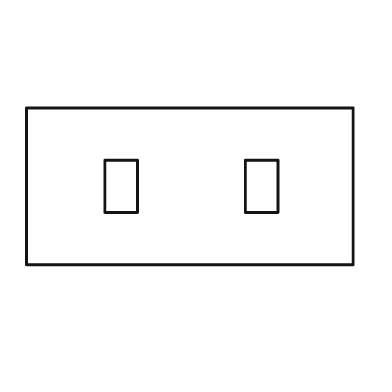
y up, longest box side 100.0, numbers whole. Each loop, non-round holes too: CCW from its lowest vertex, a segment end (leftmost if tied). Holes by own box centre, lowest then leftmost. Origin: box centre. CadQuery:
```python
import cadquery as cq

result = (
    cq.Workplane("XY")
    .moveTo(-50.0, -24.0)
    .lineTo(50.0, -24.0)
    .lineTo(50.0, 24.0)
    .lineTo(-50.0, 24.0)
    .close()
    .moveTo(-26.0, -8.0)
    .lineTo(-16.0, -8.0)
    .lineTo(-16.0, 8.0)
    .lineTo(-26.0, 8.0)
    .close()
    .moveTo(17.0, -8.0)
    .lineTo(27.0, -8.0)
    .lineTo(27.0, 8.0)
    .lineTo(17.0, 8.0)
    .close()
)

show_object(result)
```